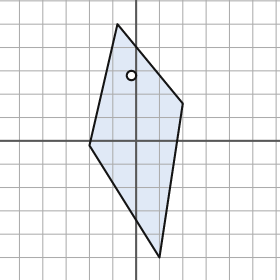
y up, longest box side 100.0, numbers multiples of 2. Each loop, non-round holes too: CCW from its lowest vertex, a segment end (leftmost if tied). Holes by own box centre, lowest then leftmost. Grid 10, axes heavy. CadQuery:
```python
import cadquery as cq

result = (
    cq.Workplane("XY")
    .moveTo(10.0, -50.0)
    .lineTo(20.0, 16.0)
    .lineTo(-8.0, 50.0)
    .lineTo(-20.0, -2.0)
    .close()
    .moveTo(-2.0, 28.0)
    .circle(2.0)
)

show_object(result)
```